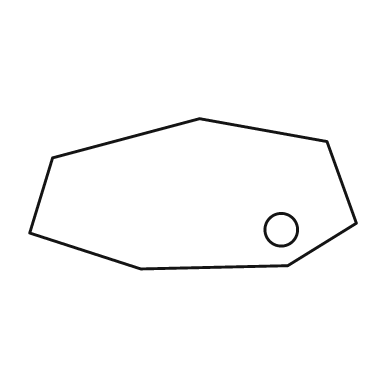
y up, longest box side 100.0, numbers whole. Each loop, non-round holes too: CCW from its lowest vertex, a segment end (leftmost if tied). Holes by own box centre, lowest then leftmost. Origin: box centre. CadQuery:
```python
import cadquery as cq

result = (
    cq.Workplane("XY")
    .moveTo(-16.0, -23.0)
    .lineTo(29.0, -22.0)
    .lineTo(50.0, -9.0)
    .lineTo(41.0, 16.0)
    .lineTo(2.0, 23.0)
    .lineTo(-43.0, 11.0)
    .lineTo(-50.0, -12.0)
    .close()
    .moveTo(27.0, -11.0)
    .circle(5.0)
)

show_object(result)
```